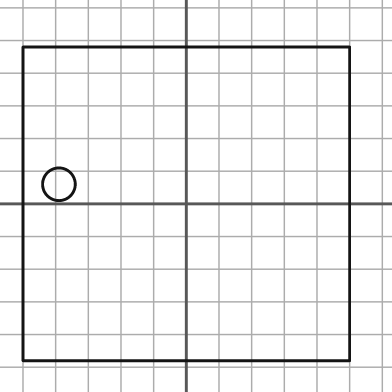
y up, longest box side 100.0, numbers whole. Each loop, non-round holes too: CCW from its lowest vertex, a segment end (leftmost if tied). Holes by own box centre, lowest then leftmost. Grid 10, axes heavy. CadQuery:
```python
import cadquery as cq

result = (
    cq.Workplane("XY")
    .moveTo(-50.0, -48.0)
    .lineTo(50.0, -48.0)
    .lineTo(50.0, 48.0)
    .lineTo(-50.0, 48.0)
    .close()
    .moveTo(-39.0, 6.0)
    .circle(5.0)
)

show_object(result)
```